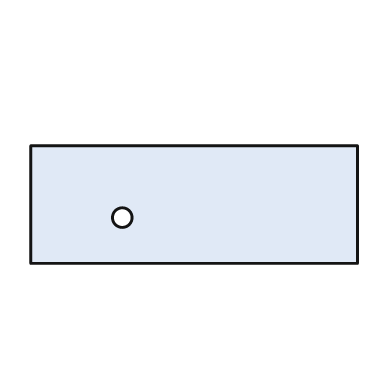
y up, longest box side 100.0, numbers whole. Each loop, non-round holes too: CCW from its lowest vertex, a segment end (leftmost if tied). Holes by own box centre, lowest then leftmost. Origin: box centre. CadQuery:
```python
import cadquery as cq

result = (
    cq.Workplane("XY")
    .moveTo(-50.0, -18.0)
    .lineTo(50.0, -18.0)
    .lineTo(50.0, 18.0)
    .lineTo(-50.0, 18.0)
    .close()
    .moveTo(-22.0, -4.0)
    .circle(3.0)
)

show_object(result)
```